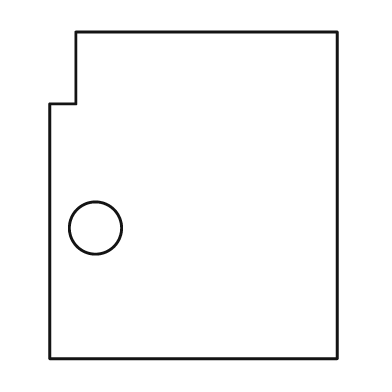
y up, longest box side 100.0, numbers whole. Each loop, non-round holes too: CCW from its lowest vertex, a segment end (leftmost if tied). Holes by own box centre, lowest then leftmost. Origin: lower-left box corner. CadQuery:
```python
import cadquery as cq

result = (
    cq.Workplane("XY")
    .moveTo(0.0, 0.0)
    .lineTo(88.0, 0.0)
    .lineTo(88.0, 100.0)
    .lineTo(8.0, 100.0)
    .lineTo(8.0, 78.0)
    .lineTo(0.0, 78.0)
    .close()
    .moveTo(14.0, 40.0)
    .circle(8.0)
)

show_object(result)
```